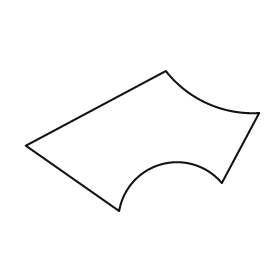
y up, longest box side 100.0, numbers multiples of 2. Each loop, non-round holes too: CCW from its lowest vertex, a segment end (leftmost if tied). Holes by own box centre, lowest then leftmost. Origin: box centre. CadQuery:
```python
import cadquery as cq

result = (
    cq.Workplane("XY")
    .moveTo(-10.0, -30.0)
    .threePointArc((8.0, -10.0), (34.0, -18.0))
    .lineTo(50.0, 12.0)
    .threePointArc((28.0, 16.0), (10.0, 30.0))
    .lineTo(-50.0, -2.0)
    .close()
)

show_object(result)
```